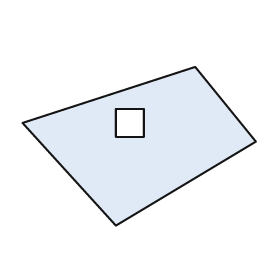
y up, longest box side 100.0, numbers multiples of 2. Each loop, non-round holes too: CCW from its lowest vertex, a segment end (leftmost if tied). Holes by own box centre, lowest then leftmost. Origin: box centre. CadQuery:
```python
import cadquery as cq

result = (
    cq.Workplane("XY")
    .moveTo(-10.0, -34.0)
    .lineTo(50.0, 2.0)
    .lineTo(24.0, 34.0)
    .lineTo(-50.0, 10.0)
    .close()
    .moveTo(-10.0, 4.0)
    .lineTo(2.0, 4.0)
    .lineTo(2.0, 16.0)
    .lineTo(-10.0, 16.0)
    .close()
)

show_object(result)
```